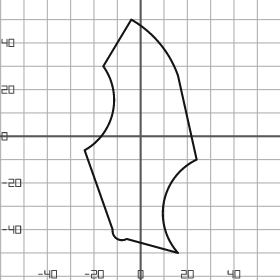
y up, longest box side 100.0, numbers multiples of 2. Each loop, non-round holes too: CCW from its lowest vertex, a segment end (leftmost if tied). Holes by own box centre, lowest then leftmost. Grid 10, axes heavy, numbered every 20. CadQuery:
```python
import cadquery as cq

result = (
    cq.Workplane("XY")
    .moveTo(16.0, -50.0)
    .threePointArc((10.0, -28.0), (24.0, -10.0))
    .lineTo(16.0, 26.0)
    .threePointArc((8.0, 40.0), (-4.0, 50.0))
    .lineTo(-16.0, 30.0)
    .threePointArc((-12.0, 10.0), (-24.0, -6.0))
    .lineTo(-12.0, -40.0)
    .threePointArc((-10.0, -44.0), (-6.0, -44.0))
    .close()
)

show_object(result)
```